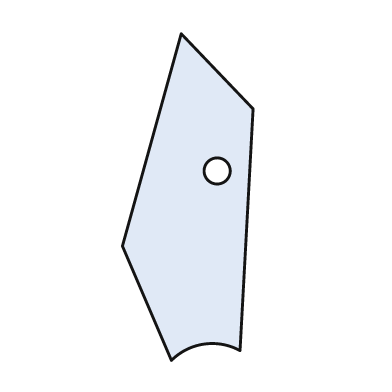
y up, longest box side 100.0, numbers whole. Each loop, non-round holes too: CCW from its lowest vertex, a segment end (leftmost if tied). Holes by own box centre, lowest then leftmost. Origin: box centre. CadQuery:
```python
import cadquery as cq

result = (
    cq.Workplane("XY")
    .moveTo(-5.0, -50.0)
    .threePointArc((5.0, -45.0), (16.0, -47.0))
    .lineTo(20.0, 27.0)
    .lineTo(-2.0, 50.0)
    .lineTo(-20.0, -15.0)
    .close()
    .moveTo(9.0, 8.0)
    .circle(4.0)
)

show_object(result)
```